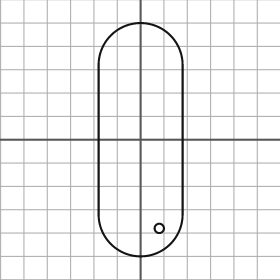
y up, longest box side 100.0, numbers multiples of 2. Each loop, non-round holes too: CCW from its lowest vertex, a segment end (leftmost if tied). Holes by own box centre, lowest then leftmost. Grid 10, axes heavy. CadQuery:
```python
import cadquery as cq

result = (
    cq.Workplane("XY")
    .moveTo(-18.0, -32.0)
    .threePointArc((0.0, -50.0), (18.0, -32.0))
    .lineTo(18.0, 32.0)
    .threePointArc((0.0, 50.0), (-18.0, 32.0))
    .close()
    .moveTo(8.0, -38.0)
    .circle(2.0)
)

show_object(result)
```